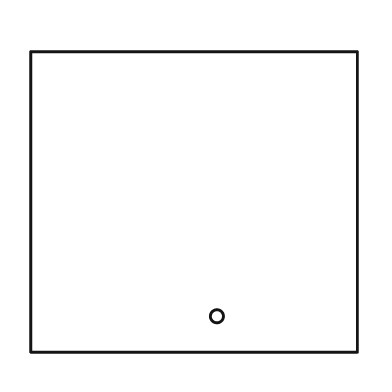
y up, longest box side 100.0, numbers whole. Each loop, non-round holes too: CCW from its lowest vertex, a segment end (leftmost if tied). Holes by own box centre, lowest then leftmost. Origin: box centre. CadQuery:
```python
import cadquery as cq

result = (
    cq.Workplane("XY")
    .moveTo(-50.0, -46.0)
    .lineTo(50.0, -46.0)
    .lineTo(50.0, 46.0)
    .lineTo(-50.0, 46.0)
    .close()
    .moveTo(7.0, -35.0)
    .circle(2.0)
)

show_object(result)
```